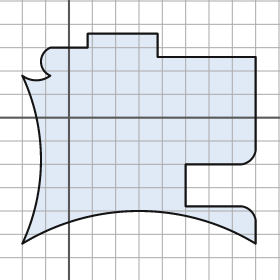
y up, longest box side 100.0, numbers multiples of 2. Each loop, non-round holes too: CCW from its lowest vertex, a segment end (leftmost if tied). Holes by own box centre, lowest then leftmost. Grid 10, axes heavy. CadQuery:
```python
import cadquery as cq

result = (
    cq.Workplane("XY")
    .moveTo(-20.0, -54.0)
    .threePointArc((30.0, -40.0), (80.0, -54.0))
    .lineTo(80.0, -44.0)
    .threePointArc((78.0, -40.0), (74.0, -38.0))
    .lineTo(50.0, -38.0)
    .lineTo(50.0, -20.0)
    .lineTo(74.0, -20.0)
    .threePointArc((78.0, -18.0), (80.0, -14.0))
    .lineTo(80.0, 26.0)
    .lineTo(38.0, 26.0)
    .lineTo(38.0, 36.0)
    .lineTo(8.0, 36.0)
    .lineTo(8.0, 30.0)
    .lineTo(-8.0, 30.0)
    .threePointArc((-12.0, 24.0), (-8.0, 18.0))
    .threePointArc((-14.0, 16.0), (-20.0, 18.0))
    .threePointArc((-12.0, -18.0), (-20.0, -54.0))
    .close()
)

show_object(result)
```